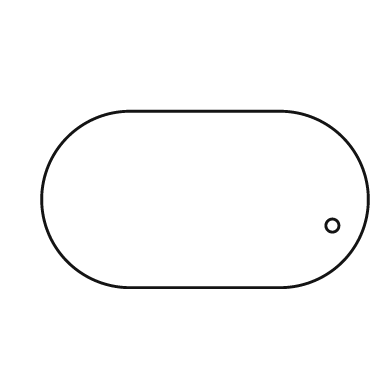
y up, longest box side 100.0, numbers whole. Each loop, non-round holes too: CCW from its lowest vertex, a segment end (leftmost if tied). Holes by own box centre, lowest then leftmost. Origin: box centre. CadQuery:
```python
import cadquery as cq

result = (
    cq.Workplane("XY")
    .moveTo(-23.0, -27.0)
    .lineTo(23.0, -27.0)
    .threePointArc((50.0, 0.0), (23.0, 27.0))
    .lineTo(-23.0, 27.0)
    .threePointArc((-50.0, 0.0), (-23.0, -27.0))
    .close()
    .moveTo(39.0, -8.0)
    .circle(2.0)
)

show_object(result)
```